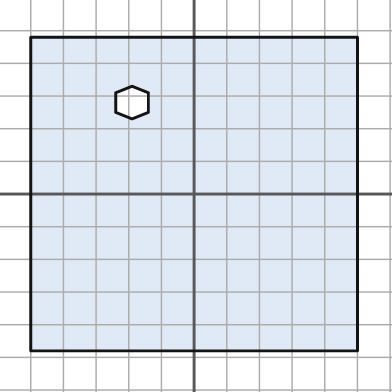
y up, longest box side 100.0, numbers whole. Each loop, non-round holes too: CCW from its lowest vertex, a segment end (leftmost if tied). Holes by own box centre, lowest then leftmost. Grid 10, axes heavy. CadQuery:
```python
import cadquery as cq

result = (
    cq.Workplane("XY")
    .moveTo(-50.0, -48.0)
    .lineTo(50.0, -48.0)
    .lineTo(50.0, 48.0)
    .lineTo(-50.0, 48.0)
    .close()
    .moveTo(-19.0, 23.0)
    .lineTo(-14.0, 25.0)
    .lineTo(-14.0, 31.0)
    .lineTo(-19.0, 33.0)
    .lineTo(-24.0, 31.0)
    .lineTo(-24.0, 25.0)
    .close()
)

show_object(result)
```